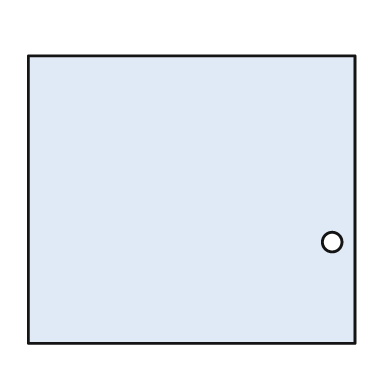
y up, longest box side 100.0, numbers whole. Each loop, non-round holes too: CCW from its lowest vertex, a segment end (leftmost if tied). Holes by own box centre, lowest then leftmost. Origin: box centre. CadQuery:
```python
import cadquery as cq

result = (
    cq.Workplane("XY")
    .moveTo(-50.0, -44.0)
    .lineTo(50.0, -44.0)
    .lineTo(50.0, 44.0)
    .lineTo(-50.0, 44.0)
    .close()
    .moveTo(43.0, -13.0)
    .circle(3.0)
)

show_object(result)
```